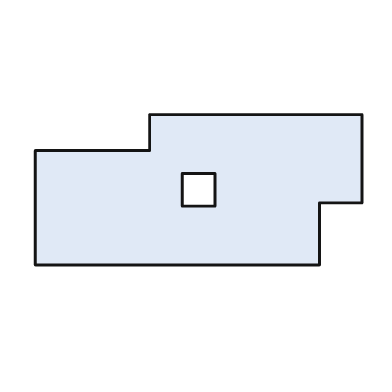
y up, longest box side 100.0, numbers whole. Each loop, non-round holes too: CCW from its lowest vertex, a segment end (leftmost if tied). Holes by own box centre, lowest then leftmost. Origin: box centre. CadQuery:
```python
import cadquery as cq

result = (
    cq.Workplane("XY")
    .moveTo(-50.0, -23.0)
    .lineTo(37.0, -23.0)
    .lineTo(37.0, -4.0)
    .lineTo(50.0, -4.0)
    .lineTo(50.0, 23.0)
    .lineTo(-15.0, 23.0)
    .lineTo(-15.0, 12.0)
    .lineTo(-50.0, 12.0)
    .close()
    .moveTo(-5.0, -5.0)
    .lineTo(5.0, -5.0)
    .lineTo(5.0, 5.0)
    .lineTo(-5.0, 5.0)
    .close()
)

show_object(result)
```